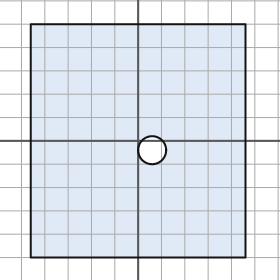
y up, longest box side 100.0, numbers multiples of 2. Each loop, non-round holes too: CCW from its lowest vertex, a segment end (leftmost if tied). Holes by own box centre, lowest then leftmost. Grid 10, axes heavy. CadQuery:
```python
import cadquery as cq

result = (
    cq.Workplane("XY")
    .moveTo(-46.0, -50.0)
    .lineTo(46.0, -50.0)
    .lineTo(46.0, 50.0)
    .lineTo(-46.0, 50.0)
    .close()
    .moveTo(6.0, -4.0)
    .circle(6.0)
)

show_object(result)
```